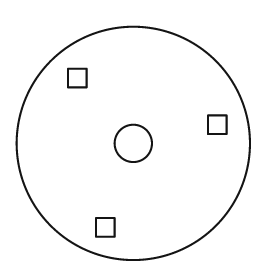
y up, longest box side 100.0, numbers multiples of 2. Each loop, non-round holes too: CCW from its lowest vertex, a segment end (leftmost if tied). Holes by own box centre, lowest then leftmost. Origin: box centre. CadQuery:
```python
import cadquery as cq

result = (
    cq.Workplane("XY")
    .moveTo(0.0, 0.0)
    .circle(50.0)
    .moveTo(-16.0, -40.0)
    .lineTo(-8.0, -40.0)
    .lineTo(-8.0, -32.0)
    .lineTo(-16.0, -32.0)
    .close()
    .moveTo(0.0, 0.0)
    .circle(8.0)
    .moveTo(32.0, 4.0)
    .lineTo(40.0, 4.0)
    .lineTo(40.0, 12.0)
    .lineTo(32.0, 12.0)
    .close()
    .moveTo(-28.0, 24.0)
    .lineTo(-20.0, 24.0)
    .lineTo(-20.0, 32.0)
    .lineTo(-28.0, 32.0)
    .close()
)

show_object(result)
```